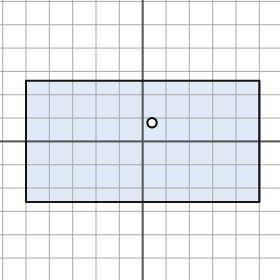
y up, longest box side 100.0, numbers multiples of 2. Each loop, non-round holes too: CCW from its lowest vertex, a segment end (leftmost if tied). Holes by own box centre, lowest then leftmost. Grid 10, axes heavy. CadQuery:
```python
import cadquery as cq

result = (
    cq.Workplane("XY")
    .moveTo(-50.0, -26.0)
    .lineTo(50.0, -26.0)
    .lineTo(50.0, 26.0)
    .lineTo(-50.0, 26.0)
    .close()
    .moveTo(4.0, 8.0)
    .circle(2.0)
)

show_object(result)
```